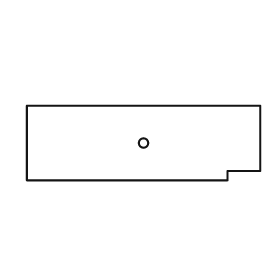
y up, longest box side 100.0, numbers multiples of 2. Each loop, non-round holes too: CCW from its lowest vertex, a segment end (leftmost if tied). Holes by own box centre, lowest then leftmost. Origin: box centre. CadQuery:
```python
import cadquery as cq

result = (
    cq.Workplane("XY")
    .moveTo(-50.0, -16.0)
    .lineTo(36.0, -16.0)
    .lineTo(36.0, -12.0)
    .lineTo(50.0, -12.0)
    .lineTo(50.0, 16.0)
    .lineTo(-50.0, 16.0)
    .close()
    .moveTo(0.0, 0.0)
    .circle(2.0)
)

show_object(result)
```